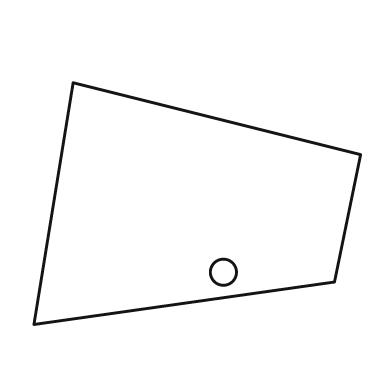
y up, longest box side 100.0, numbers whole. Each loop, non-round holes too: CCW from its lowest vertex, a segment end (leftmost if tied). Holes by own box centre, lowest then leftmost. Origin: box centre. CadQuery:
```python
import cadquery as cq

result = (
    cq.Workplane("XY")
    .moveTo(-50.0, -37.0)
    .lineTo(42.0, -24.0)
    .lineTo(50.0, 15.0)
    .lineTo(-38.0, 37.0)
    .close()
    .moveTo(8.0, -21.0)
    .circle(4.0)
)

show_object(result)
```